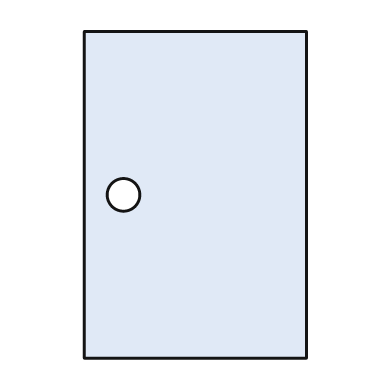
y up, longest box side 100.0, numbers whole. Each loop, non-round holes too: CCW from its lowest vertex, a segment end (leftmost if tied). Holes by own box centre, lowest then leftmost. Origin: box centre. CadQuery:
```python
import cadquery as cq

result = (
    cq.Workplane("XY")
    .moveTo(-34.0, -50.0)
    .lineTo(34.0, -50.0)
    .lineTo(34.0, 50.0)
    .lineTo(-34.0, 50.0)
    .close()
    .moveTo(-22.0, 0.0)
    .circle(5.0)
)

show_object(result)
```